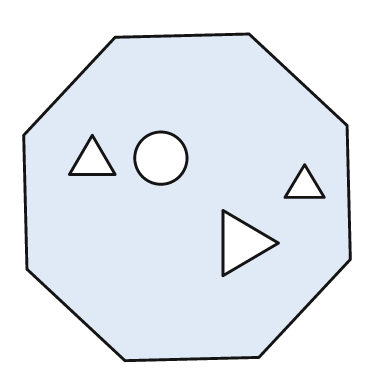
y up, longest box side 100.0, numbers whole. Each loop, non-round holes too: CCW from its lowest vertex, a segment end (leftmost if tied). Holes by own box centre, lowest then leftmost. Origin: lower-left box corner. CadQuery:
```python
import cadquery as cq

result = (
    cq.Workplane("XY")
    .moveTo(31.0, 0.0)
    .lineTo(72.0, 1.0)
    .lineTo(100.0, 31.0)
    .lineTo(99.0, 72.0)
    .lineTo(69.0, 100.0)
    .lineTo(28.0, 99.0)
    .lineTo(0.0, 69.0)
    .lineTo(1.0, 28.0)
    .close()
    .moveTo(61.0, 26.0)
    .lineTo(78.0, 36.0)
    .lineTo(61.0, 46.0)
    .close()
    .moveTo(80.0, 50.0)
    .lineTo(92.0, 50.0)
    .lineTo(86.0, 60.0)
    .close()
    .moveTo(42.0, 62.0)
    .circle(8.0)
    .moveTo(14.0, 57.0)
    .lineTo(28.0, 57.0)
    .lineTo(21.0, 69.0)
    .close()
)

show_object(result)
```